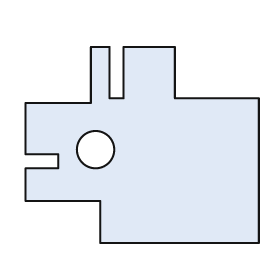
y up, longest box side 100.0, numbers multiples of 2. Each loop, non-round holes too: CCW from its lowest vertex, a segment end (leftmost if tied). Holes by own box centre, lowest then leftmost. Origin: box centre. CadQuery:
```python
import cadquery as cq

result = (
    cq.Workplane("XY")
    .moveTo(-18.0, -42.0)
    .lineTo(50.0, -42.0)
    .lineTo(50.0, 20.0)
    .lineTo(14.0, 20.0)
    .lineTo(14.0, 42.0)
    .lineTo(-8.0, 42.0)
    .lineTo(-8.0, 20.0)
    .lineTo(-14.0, 20.0)
    .lineTo(-14.0, 42.0)
    .lineTo(-22.0, 42.0)
    .lineTo(-22.0, 18.0)
    .lineTo(-50.0, 18.0)
    .lineTo(-50.0, -4.0)
    .lineTo(-36.0, -4.0)
    .lineTo(-36.0, -10.0)
    .lineTo(-50.0, -10.0)
    .lineTo(-50.0, -24.0)
    .lineTo(-18.0, -24.0)
    .close()
    .moveTo(-20.0, -2.0)
    .circle(8.0)
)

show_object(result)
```